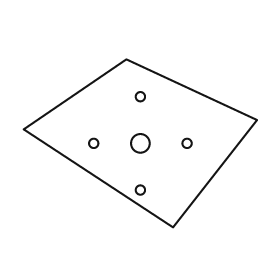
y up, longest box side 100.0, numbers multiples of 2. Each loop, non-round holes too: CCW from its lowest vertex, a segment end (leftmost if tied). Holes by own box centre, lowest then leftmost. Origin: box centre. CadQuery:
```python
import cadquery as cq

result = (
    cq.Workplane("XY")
    .moveTo(14.0, -36.0)
    .lineTo(50.0, 10.0)
    .lineTo(-6.0, 36.0)
    .lineTo(-50.0, 6.0)
    .close()
    .moveTo(0.0, -20.0)
    .circle(2.0)
    .moveTo(-20.0, 0.0)
    .circle(2.0)
    .moveTo(0.0, 0.0)
    .circle(4.0)
    .moveTo(20.0, 0.0)
    .circle(2.0)
    .moveTo(0.0, 20.0)
    .circle(2.0)
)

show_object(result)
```